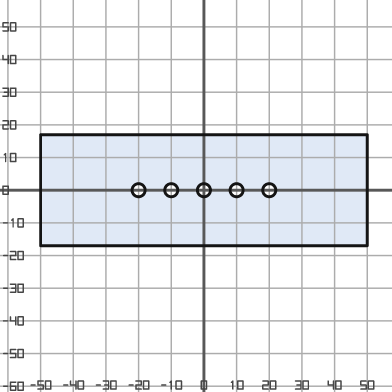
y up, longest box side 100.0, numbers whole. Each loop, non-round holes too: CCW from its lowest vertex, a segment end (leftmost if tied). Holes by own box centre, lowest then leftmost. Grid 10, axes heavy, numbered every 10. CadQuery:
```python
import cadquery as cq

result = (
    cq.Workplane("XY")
    .moveTo(-50.0, -17.0)
    .lineTo(50.0, -17.0)
    .lineTo(50.0, 17.0)
    .lineTo(-50.0, 17.0)
    .close()
    .moveTo(-20.0, 0.0)
    .circle(2.0)
    .moveTo(-10.0, 0.0)
    .circle(2.0)
    .moveTo(0.0, 0.0)
    .circle(2.0)
    .moveTo(10.0, 0.0)
    .circle(2.0)
    .moveTo(20.0, 0.0)
    .circle(2.0)
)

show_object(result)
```